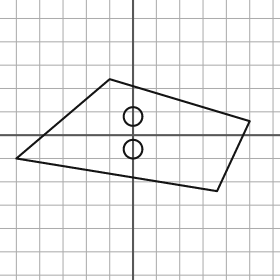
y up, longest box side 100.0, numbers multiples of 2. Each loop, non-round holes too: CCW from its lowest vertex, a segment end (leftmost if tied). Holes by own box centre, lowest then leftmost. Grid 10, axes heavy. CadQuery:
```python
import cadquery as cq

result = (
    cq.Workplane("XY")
    .moveTo(36.0, -24.0)
    .lineTo(50.0, 6.0)
    .lineTo(-10.0, 24.0)
    .lineTo(-50.0, -10.0)
    .close()
    .moveTo(0.0, -6.0)
    .circle(4.0)
    .moveTo(0.0, 8.0)
    .circle(4.0)
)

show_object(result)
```